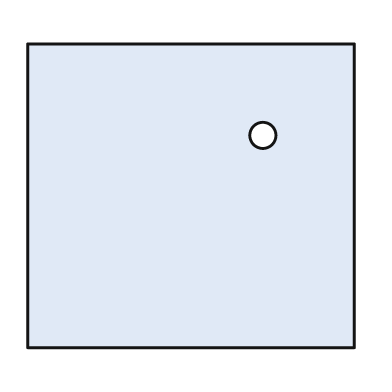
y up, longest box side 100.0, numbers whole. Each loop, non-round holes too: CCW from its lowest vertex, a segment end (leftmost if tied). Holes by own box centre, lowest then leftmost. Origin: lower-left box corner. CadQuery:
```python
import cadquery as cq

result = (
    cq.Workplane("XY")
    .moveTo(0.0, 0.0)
    .lineTo(100.0, 0.0)
    .lineTo(100.0, 93.0)
    .lineTo(0.0, 93.0)
    .close()
    .moveTo(72.0, 65.0)
    .circle(4.0)
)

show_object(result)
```